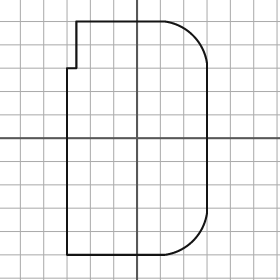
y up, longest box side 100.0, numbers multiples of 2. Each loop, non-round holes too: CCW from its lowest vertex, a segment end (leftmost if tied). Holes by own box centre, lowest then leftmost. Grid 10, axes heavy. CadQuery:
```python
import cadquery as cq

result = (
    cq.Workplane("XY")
    .moveTo(-30.0, -50.0)
    .lineTo(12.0, -50.0)
    .threePointArc((24.0, -44.0), (30.0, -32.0))
    .lineTo(30.0, 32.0)
    .threePointArc((24.0, 44.0), (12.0, 50.0))
    .lineTo(-26.0, 50.0)
    .lineTo(-26.0, 30.0)
    .lineTo(-30.0, 30.0)
    .close()
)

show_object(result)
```